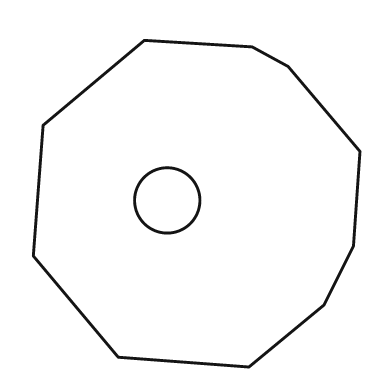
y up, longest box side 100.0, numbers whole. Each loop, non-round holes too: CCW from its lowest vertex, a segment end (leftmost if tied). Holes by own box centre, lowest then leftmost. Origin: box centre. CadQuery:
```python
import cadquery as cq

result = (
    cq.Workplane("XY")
    .moveTo(16.0, -50.0)
    .lineTo(39.0, -31.0)
    .lineTo(48.0, -13.0)
    .lineTo(50.0, 16.0)
    .lineTo(28.0, 42.0)
    .lineTo(17.0, 48.0)
    .lineTo(-16.0, 50.0)
    .lineTo(-47.0, 24.0)
    .lineTo(-50.0, -16.0)
    .lineTo(-24.0, -47.0)
    .close()
    .moveTo(-9.0, 1.0)
    .circle(10.0)
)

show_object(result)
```